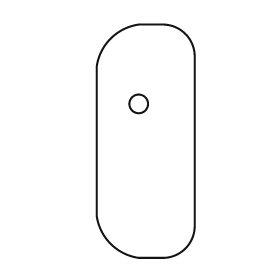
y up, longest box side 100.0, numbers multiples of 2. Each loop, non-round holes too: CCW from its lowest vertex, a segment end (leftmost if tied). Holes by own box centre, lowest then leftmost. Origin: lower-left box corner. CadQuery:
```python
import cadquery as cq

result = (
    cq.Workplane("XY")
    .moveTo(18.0, 0.0)
    .lineTo(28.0, 0.0)
    .threePointArc((38.0, 4.0), (42.0, 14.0))
    .lineTo(42.0, 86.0)
    .threePointArc((38.0, 96.0), (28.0, 100.0))
    .lineTo(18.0, 100.0)
    .threePointArc((6.0, 94.0), (0.0, 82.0))
    .lineTo(0.0, 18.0)
    .threePointArc((6.0, 6.0), (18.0, 0.0))
    .close()
    .moveTo(18.0, 66.0)
    .circle(4.0)
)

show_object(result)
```